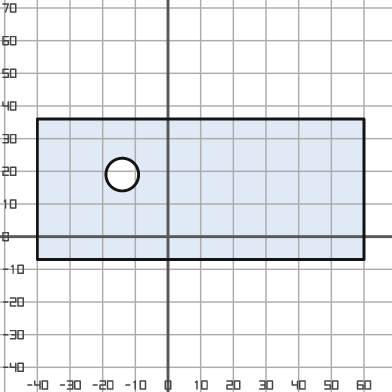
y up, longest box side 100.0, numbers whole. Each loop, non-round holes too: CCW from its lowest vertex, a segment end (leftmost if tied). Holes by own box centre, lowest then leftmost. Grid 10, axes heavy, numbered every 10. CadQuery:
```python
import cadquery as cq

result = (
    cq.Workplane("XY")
    .moveTo(-40.0, -7.0)
    .lineTo(60.0, -7.0)
    .lineTo(60.0, 36.0)
    .lineTo(-40.0, 36.0)
    .close()
    .moveTo(-14.0, 19.0)
    .circle(5.0)
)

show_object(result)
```